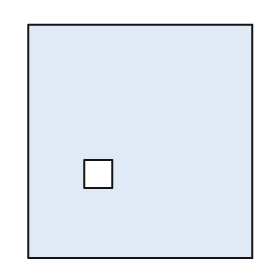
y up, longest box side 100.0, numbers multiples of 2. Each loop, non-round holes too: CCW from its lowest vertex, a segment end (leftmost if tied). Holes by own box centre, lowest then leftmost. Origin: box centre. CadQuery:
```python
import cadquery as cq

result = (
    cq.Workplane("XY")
    .moveTo(-48.0, -50.0)
    .lineTo(48.0, -50.0)
    .lineTo(48.0, 50.0)
    .lineTo(-48.0, 50.0)
    .close()
    .moveTo(-24.0, -20.0)
    .lineTo(-12.0, -20.0)
    .lineTo(-12.0, -8.0)
    .lineTo(-24.0, -8.0)
    .close()
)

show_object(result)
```